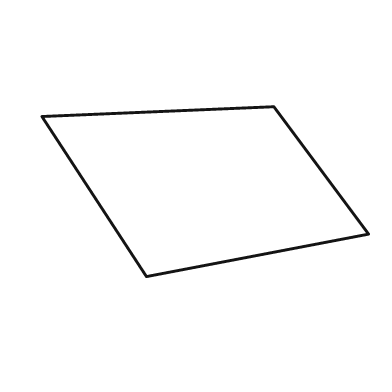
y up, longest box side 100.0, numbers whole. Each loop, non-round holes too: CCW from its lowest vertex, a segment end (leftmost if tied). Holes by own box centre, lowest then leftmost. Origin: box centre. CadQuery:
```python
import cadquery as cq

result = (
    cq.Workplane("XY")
    .moveTo(-18.0, -26.0)
    .lineTo(50.0, -13.0)
    .lineTo(21.0, 26.0)
    .lineTo(-50.0, 23.0)
    .close()
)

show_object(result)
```